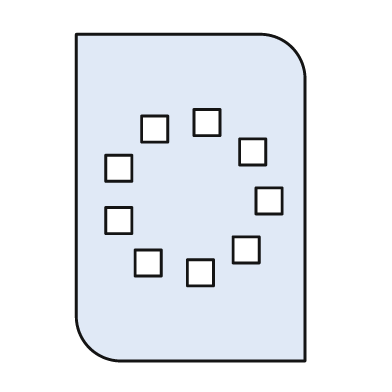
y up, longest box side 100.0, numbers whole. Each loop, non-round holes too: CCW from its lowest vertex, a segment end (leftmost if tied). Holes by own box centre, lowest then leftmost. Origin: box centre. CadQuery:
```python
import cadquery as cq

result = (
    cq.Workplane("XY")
    .moveTo(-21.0, -50.0)
    .lineTo(35.0, -50.0)
    .lineTo(35.0, 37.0)
    .threePointArc((31.0, 46.0), (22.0, 50.0))
    .lineTo(-35.0, 50.0)
    .lineTo(-35.0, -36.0)
    .threePointArc((-31.0, -46.0), (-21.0, -50.0))
    .close()
    .moveTo(-1.0, -27.0)
    .lineTo(7.0, -27.0)
    .lineTo(7.0, -19.0)
    .lineTo(-1.0, -19.0)
    .close()
    .moveTo(-17.0, -24.0)
    .lineTo(-9.0, -24.0)
    .lineTo(-9.0, -16.0)
    .lineTo(-17.0, -16.0)
    .close()
    .moveTo(13.0, -20.0)
    .lineTo(21.0, -20.0)
    .lineTo(21.0, -12.0)
    .lineTo(13.0, -12.0)
    .close()
    .moveTo(-26.0, -11.0)
    .lineTo(-18.0, -11.0)
    .lineTo(-18.0, -3.0)
    .lineTo(-26.0, -3.0)
    .close()
    .moveTo(20.0, -5.0)
    .lineTo(28.0, -5.0)
    .lineTo(28.0, 3.0)
    .lineTo(20.0, 3.0)
    .close()
    .moveTo(-26.0, 5.0)
    .lineTo(-18.0, 5.0)
    .lineTo(-18.0, 13.0)
    .lineTo(-26.0, 13.0)
    .close()
    .moveTo(15.0, 10.0)
    .lineTo(23.0, 10.0)
    .lineTo(23.0, 18.0)
    .lineTo(15.0, 18.0)
    .close()
    .moveTo(-15.0, 17.0)
    .lineTo(-7.0, 17.0)
    .lineTo(-7.0, 25.0)
    .lineTo(-15.0, 25.0)
    .close()
    .moveTo(1.0, 19.0)
    .lineTo(9.0, 19.0)
    .lineTo(9.0, 27.0)
    .lineTo(1.0, 27.0)
    .close()
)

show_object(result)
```